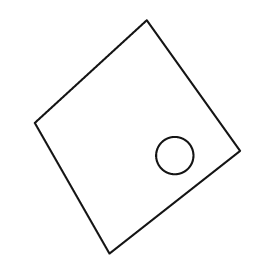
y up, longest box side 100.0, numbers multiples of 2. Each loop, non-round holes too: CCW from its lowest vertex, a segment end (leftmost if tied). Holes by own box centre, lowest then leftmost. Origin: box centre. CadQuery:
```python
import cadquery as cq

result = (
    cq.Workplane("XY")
    .moveTo(-12.0, -50.0)
    .lineTo(44.0, -6.0)
    .lineTo(4.0, 50.0)
    .lineTo(-44.0, 6.0)
    .close()
    .moveTo(16.0, -8.0)
    .circle(8.0)
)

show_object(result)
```